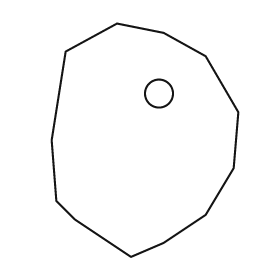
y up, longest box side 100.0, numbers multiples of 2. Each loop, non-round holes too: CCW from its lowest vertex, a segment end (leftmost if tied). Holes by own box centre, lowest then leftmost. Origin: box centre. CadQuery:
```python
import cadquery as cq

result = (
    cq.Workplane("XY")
    .moveTo(-6.0, -50.0)
    .lineTo(8.0, -44.0)
    .lineTo(26.0, -32.0)
    .lineTo(38.0, -12.0)
    .lineTo(40.0, 12.0)
    .lineTo(26.0, 36.0)
    .lineTo(8.0, 46.0)
    .lineTo(-12.0, 50.0)
    .lineTo(-34.0, 38.0)
    .lineTo(-40.0, 0.0)
    .lineTo(-38.0, -26.0)
    .lineTo(-30.0, -34.0)
    .close()
    .moveTo(6.0, 20.0)
    .circle(6.0)
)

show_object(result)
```